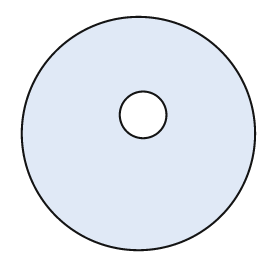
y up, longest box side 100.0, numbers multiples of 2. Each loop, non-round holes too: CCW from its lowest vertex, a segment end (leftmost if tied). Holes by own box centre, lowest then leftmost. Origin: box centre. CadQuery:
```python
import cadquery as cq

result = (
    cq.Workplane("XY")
    .moveTo(0.0, 0.0)
    .circle(50.0)
    .moveTo(2.0, 8.0)
    .circle(10.0)
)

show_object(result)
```